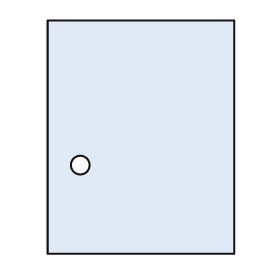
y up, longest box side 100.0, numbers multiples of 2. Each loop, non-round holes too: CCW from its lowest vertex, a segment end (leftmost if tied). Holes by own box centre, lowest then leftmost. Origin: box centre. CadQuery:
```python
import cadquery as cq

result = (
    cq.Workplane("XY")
    .moveTo(-40.0, -50.0)
    .lineTo(40.0, -50.0)
    .lineTo(40.0, 50.0)
    .lineTo(-40.0, 50.0)
    .close()
    .moveTo(-26.0, -12.0)
    .circle(4.0)
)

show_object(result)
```